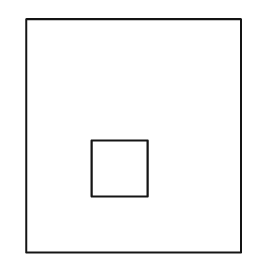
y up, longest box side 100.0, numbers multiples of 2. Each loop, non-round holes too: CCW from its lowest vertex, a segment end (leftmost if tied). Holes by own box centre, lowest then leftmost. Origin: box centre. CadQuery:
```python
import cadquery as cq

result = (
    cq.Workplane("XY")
    .moveTo(-46.0, -50.0)
    .lineTo(46.0, -50.0)
    .lineTo(46.0, 50.0)
    .lineTo(-46.0, 50.0)
    .close()
    .moveTo(-18.0, -26.0)
    .lineTo(6.0, -26.0)
    .lineTo(6.0, -2.0)
    .lineTo(-18.0, -2.0)
    .close()
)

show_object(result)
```